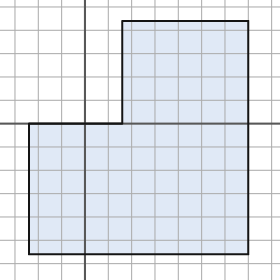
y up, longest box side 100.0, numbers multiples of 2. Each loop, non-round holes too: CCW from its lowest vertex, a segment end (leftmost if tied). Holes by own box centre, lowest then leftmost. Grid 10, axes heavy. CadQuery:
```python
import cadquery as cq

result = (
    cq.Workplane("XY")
    .moveTo(-24.0, -56.0)
    .lineTo(70.0, -56.0)
    .lineTo(70.0, 44.0)
    .lineTo(16.0, 44.0)
    .lineTo(16.0, 0.0)
    .lineTo(-24.0, 0.0)
    .close()
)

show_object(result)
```